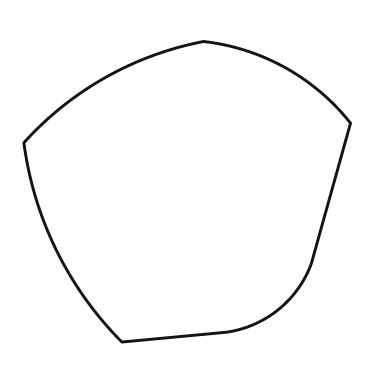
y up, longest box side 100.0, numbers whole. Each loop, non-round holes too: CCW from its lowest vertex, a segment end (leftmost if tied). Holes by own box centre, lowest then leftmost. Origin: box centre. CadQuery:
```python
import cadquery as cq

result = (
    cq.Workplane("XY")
    .moveTo(-20.0, -46.0)
    .lineTo(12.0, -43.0)
    .threePointArc((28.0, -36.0), (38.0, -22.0))
    .lineTo(50.0, 21.0)
    .threePointArc((30.0, 38.0), (5.0, 46.0))
    .threePointArc((-25.0, 35.0), (-50.0, 15.0))
    .threePointArc((-40.0, -18.0), (-20.0, -46.0))
    .close()
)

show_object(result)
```